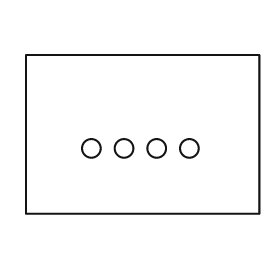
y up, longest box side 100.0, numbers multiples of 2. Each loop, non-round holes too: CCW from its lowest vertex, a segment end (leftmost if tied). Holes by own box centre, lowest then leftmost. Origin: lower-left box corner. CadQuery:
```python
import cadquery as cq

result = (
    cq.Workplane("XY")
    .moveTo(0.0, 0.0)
    .lineTo(100.0, 0.0)
    .lineTo(100.0, 68.0)
    .lineTo(0.0, 68.0)
    .close()
    .moveTo(28.0, 28.0)
    .circle(4.0)
    .moveTo(42.0, 28.0)
    .circle(4.0)
    .moveTo(56.0, 28.0)
    .circle(4.0)
    .moveTo(70.0, 28.0)
    .circle(4.0)
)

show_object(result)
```